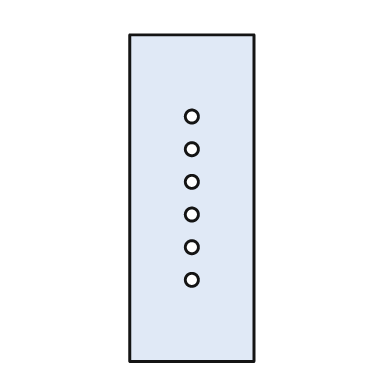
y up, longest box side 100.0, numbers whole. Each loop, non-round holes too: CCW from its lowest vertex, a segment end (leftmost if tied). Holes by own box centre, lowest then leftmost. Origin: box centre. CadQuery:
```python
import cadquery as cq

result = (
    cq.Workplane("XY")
    .moveTo(-19.0, -50.0)
    .lineTo(19.0, -50.0)
    .lineTo(19.0, 50.0)
    .lineTo(-19.0, 50.0)
    .close()
    .moveTo(0.0, -25.0)
    .circle(2.0)
    .moveTo(0.0, -15.0)
    .circle(2.0)
    .moveTo(0.0, -5.0)
    .circle(2.0)
    .moveTo(0.0, 5.0)
    .circle(2.0)
    .moveTo(0.0, 15.0)
    .circle(2.0)
    .moveTo(0.0, 25.0)
    .circle(2.0)
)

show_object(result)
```